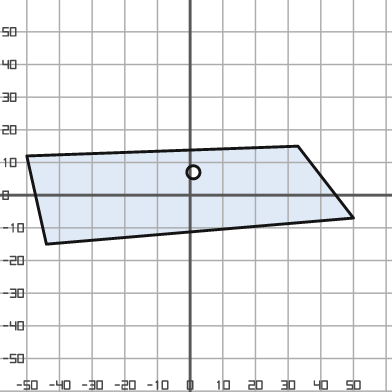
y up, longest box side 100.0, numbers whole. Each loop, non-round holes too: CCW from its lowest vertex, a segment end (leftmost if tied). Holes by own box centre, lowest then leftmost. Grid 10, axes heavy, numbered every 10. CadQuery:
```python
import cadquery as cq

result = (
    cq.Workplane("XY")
    .moveTo(-44.0, -15.0)
    .lineTo(50.0, -7.0)
    .lineTo(33.0, 15.0)
    .lineTo(-50.0, 12.0)
    .close()
    .moveTo(1.0, 7.0)
    .circle(2.0)
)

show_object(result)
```